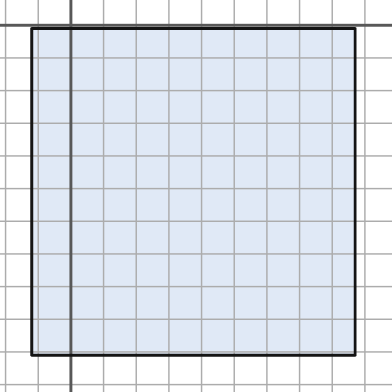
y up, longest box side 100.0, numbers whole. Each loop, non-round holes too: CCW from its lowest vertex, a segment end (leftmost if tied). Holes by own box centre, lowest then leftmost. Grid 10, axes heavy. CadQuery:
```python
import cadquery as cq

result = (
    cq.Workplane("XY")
    .moveTo(-12.0, -101.0)
    .lineTo(87.0, -101.0)
    .lineTo(87.0, -1.0)
    .lineTo(-12.0, -1.0)
    .close()
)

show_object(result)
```